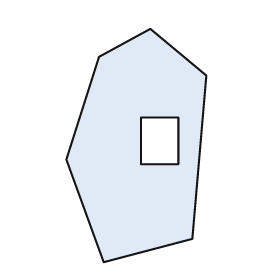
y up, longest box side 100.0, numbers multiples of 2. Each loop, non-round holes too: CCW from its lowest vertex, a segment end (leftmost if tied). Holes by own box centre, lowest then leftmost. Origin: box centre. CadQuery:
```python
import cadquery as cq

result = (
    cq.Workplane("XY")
    .moveTo(-14.0, -50.0)
    .lineTo(24.0, -40.0)
    .lineTo(30.0, 30.0)
    .lineTo(6.0, 50.0)
    .lineTo(-16.0, 38.0)
    .lineTo(-30.0, -6.0)
    .close()
    .moveTo(2.0, -8.0)
    .lineTo(18.0, -8.0)
    .lineTo(18.0, 12.0)
    .lineTo(2.0, 12.0)
    .close()
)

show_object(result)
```